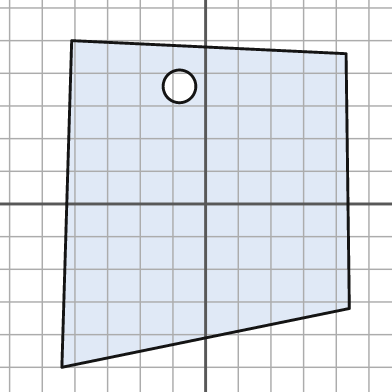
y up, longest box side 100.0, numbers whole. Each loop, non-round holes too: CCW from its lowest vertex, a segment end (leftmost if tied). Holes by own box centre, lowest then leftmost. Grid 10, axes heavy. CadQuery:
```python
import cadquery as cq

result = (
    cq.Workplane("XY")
    .moveTo(-44.0, -50.0)
    .lineTo(44.0, -32.0)
    .lineTo(43.0, 46.0)
    .lineTo(-41.0, 50.0)
    .close()
    .moveTo(-8.0, 36.0)
    .circle(5.0)
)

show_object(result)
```